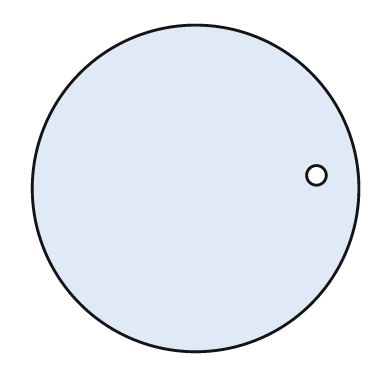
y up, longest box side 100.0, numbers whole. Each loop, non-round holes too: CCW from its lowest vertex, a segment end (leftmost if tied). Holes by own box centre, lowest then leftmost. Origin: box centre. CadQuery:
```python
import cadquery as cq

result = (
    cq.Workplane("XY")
    .moveTo(0.0, 0.0)
    .circle(50.0)
    .moveTo(37.0, 4.0)
    .circle(3.0)
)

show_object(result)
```